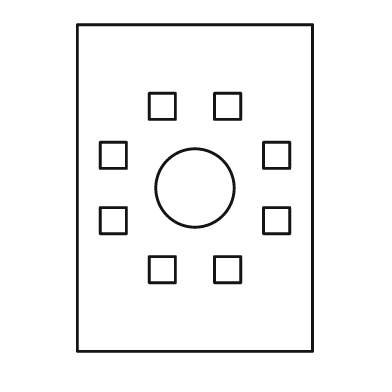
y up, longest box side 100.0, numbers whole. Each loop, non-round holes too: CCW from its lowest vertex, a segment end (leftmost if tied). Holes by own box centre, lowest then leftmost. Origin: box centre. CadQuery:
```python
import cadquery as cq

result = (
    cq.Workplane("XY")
    .moveTo(-36.0, -50.0)
    .lineTo(36.0, -50.0)
    .lineTo(36.0, 50.0)
    .lineTo(-36.0, 50.0)
    .close()
    .moveTo(-14.0, -29.0)
    .lineTo(-6.0, -29.0)
    .lineTo(-6.0, -21.0)
    .lineTo(-14.0, -21.0)
    .close()
    .moveTo(6.0, -29.0)
    .lineTo(14.0, -29.0)
    .lineTo(14.0, -21.0)
    .lineTo(6.0, -21.0)
    .close()
    .moveTo(-29.0, -14.0)
    .lineTo(-21.0, -14.0)
    .lineTo(-21.0, -6.0)
    .lineTo(-29.0, -6.0)
    .close()
    .moveTo(21.0, -14.0)
    .lineTo(29.0, -14.0)
    .lineTo(29.0, -6.0)
    .lineTo(21.0, -6.0)
    .close()
    .moveTo(0.0, 0.0)
    .circle(12.0)
    .moveTo(-29.0, 6.0)
    .lineTo(-21.0, 6.0)
    .lineTo(-21.0, 14.0)
    .lineTo(-29.0, 14.0)
    .close()
    .moveTo(21.0, 6.0)
    .lineTo(29.0, 6.0)
    .lineTo(29.0, 14.0)
    .lineTo(21.0, 14.0)
    .close()
    .moveTo(-14.0, 21.0)
    .lineTo(-6.0, 21.0)
    .lineTo(-6.0, 29.0)
    .lineTo(-14.0, 29.0)
    .close()
    .moveTo(6.0, 21.0)
    .lineTo(14.0, 21.0)
    .lineTo(14.0, 29.0)
    .lineTo(6.0, 29.0)
    .close()
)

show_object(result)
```